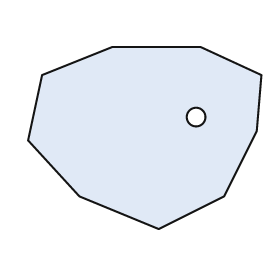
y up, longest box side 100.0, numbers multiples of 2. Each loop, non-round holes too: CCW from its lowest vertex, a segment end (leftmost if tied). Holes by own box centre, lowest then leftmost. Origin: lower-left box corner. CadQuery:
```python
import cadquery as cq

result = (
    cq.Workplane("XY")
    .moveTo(56.0, 0.0)
    .lineTo(84.0, 14.0)
    .lineTo(98.0, 42.0)
    .lineTo(100.0, 66.0)
    .lineTo(74.0, 78.0)
    .lineTo(36.0, 78.0)
    .lineTo(6.0, 66.0)
    .lineTo(0.0, 38.0)
    .lineTo(22.0, 14.0)
    .close()
    .moveTo(72.0, 48.0)
    .circle(4.0)
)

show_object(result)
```